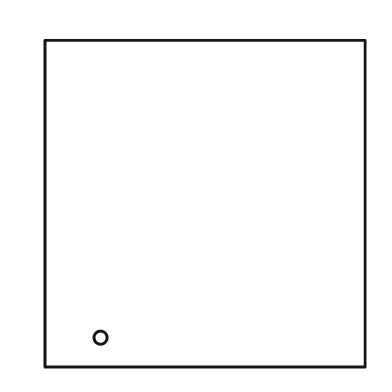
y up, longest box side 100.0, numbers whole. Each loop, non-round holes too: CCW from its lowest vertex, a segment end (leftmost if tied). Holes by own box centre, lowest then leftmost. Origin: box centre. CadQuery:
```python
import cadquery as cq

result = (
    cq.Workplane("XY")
    .moveTo(-49.0, -50.0)
    .lineTo(49.0, -50.0)
    .lineTo(49.0, 50.0)
    .lineTo(-49.0, 50.0)
    .close()
    .moveTo(-32.0, -41.0)
    .circle(2.0)
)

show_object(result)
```